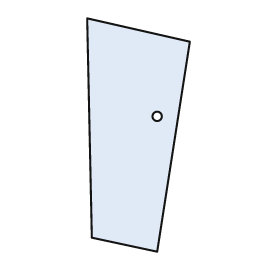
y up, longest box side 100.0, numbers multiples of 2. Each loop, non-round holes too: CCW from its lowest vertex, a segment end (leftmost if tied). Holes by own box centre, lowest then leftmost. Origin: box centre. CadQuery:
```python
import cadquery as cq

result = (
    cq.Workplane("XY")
    .moveTo(8.0, -50.0)
    .lineTo(22.0, 40.0)
    .lineTo(-22.0, 50.0)
    .lineTo(-20.0, -44.0)
    .close()
    .moveTo(8.0, 8.0)
    .circle(2.0)
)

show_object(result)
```